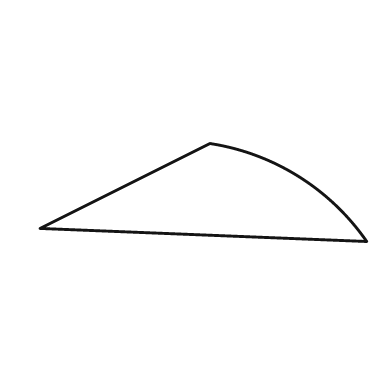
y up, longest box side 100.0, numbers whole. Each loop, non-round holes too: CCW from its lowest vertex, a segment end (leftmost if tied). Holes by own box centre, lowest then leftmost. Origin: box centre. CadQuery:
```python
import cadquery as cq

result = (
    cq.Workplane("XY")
    .moveTo(50.0, -15.0)
    .threePointArc((29.0, 5.0), (2.0, 15.0))
    .lineTo(-50.0, -11.0)
    .close()
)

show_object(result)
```